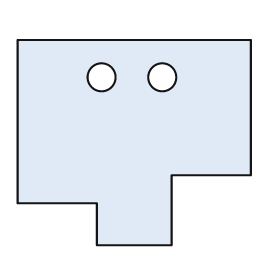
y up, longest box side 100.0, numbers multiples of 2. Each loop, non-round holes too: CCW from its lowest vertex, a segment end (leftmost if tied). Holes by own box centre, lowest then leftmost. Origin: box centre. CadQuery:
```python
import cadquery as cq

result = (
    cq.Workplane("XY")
    .moveTo(-16.0, -44.0)
    .lineTo(16.0, -44.0)
    .lineTo(16.0, -14.0)
    .lineTo(50.0, -14.0)
    .lineTo(50.0, 44.0)
    .lineTo(-50.0, 44.0)
    .lineTo(-50.0, -26.0)
    .lineTo(-16.0, -26.0)
    .close()
    .moveTo(-14.0, 28.0)
    .circle(6.0)
    .moveTo(12.0, 28.0)
    .circle(6.0)
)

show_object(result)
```